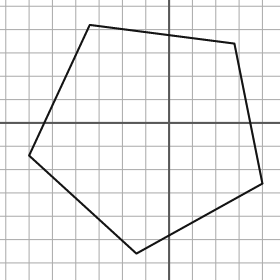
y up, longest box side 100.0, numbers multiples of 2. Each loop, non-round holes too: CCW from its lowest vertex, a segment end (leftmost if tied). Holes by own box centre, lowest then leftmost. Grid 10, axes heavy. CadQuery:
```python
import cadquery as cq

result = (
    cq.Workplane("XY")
    .moveTo(-14.0, -56.0)
    .lineTo(40.0, -26.0)
    .lineTo(28.0, 34.0)
    .lineTo(-34.0, 42.0)
    .lineTo(-60.0, -14.0)
    .close()
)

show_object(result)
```